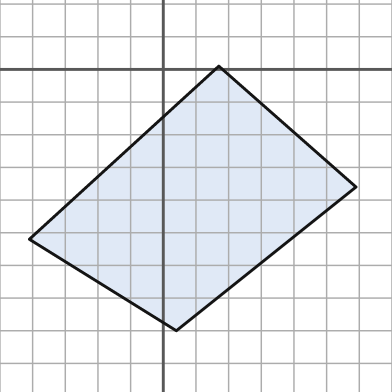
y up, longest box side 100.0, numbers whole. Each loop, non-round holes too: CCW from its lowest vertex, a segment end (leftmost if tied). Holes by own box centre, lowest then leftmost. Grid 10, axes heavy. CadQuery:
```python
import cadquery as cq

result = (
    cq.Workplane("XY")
    .moveTo(4.0, -80.0)
    .lineTo(59.0, -36.0)
    .lineTo(17.0, 1.0)
    .lineTo(-41.0, -52.0)
    .close()
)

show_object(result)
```